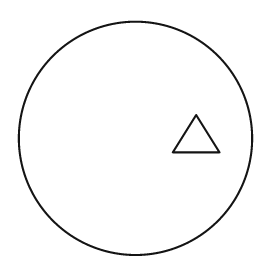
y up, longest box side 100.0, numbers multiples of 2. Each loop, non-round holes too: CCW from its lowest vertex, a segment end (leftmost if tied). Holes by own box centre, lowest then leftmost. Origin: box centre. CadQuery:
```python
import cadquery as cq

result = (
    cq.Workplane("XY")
    .moveTo(0.0, 0.0)
    .circle(50.0)
    .moveTo(16.0, -6.0)
    .lineTo(36.0, -6.0)
    .lineTo(26.0, 10.0)
    .close()
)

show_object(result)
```